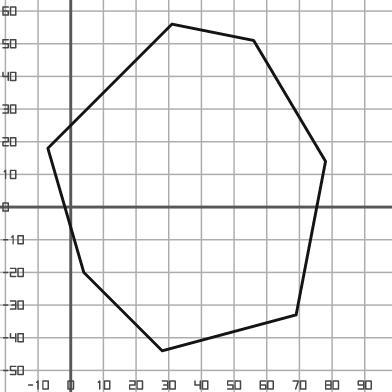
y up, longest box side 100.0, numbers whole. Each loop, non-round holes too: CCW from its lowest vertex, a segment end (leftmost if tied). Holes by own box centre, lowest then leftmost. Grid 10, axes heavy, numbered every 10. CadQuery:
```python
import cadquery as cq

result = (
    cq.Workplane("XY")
    .moveTo(28.0, -44.0)
    .lineTo(69.0, -33.0)
    .lineTo(78.0, 14.0)
    .lineTo(56.0, 51.0)
    .lineTo(31.0, 56.0)
    .lineTo(-7.0, 18.0)
    .lineTo(4.0, -20.0)
    .close()
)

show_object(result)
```